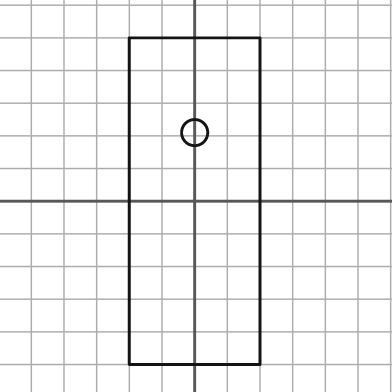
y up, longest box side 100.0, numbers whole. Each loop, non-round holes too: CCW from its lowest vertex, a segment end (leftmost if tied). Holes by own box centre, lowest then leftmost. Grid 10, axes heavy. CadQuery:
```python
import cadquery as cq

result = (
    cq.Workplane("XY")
    .moveTo(-20.0, -50.0)
    .lineTo(20.0, -50.0)
    .lineTo(20.0, 50.0)
    .lineTo(-20.0, 50.0)
    .close()
    .moveTo(0.0, 21.0)
    .circle(4.0)
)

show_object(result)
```